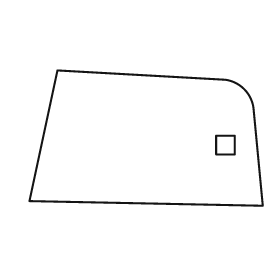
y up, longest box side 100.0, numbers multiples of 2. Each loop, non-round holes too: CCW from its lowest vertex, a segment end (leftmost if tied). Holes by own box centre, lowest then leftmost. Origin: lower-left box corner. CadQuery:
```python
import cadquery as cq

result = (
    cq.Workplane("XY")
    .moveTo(100.0, 0.0)
    .lineTo(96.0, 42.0)
    .threePointArc((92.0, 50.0), (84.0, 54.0))
    .lineTo(12.0, 58.0)
    .lineTo(0.0, 2.0)
    .close()
    .moveTo(80.0, 22.0)
    .lineTo(88.0, 22.0)
    .lineTo(88.0, 30.0)
    .lineTo(80.0, 30.0)
    .close()
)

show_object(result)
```